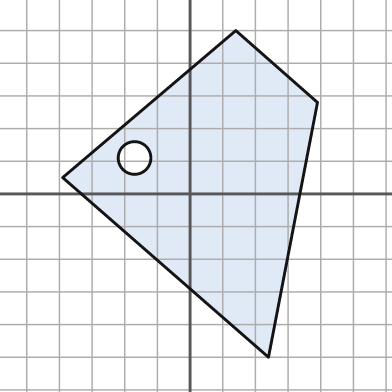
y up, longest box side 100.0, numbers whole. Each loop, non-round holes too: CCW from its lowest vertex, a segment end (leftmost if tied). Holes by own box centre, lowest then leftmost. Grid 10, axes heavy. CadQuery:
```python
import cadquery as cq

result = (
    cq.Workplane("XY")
    .moveTo(24.0, -50.0)
    .lineTo(39.0, 28.0)
    .lineTo(14.0, 50.0)
    .lineTo(-39.0, 5.0)
    .close()
    .moveTo(-17.0, 11.0)
    .circle(5.0)
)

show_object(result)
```